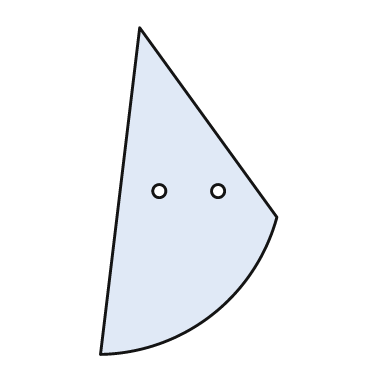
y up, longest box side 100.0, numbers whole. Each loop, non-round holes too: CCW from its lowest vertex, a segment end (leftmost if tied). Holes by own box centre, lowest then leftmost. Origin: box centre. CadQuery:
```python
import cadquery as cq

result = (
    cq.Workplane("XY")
    .moveTo(-27.0, -50.0)
    .threePointArc((7.0, -38.0), (27.0, -8.0))
    .lineTo(-15.0, 50.0)
    .close()
    .moveTo(-9.0, 0.0)
    .circle(2.0)
    .moveTo(9.0, 0.0)
    .circle(2.0)
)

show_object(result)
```